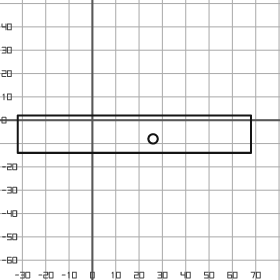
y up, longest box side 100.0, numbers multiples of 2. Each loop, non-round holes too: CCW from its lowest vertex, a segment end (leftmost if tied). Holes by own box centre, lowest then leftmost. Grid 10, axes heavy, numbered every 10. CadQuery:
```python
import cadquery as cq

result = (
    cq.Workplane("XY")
    .moveTo(-32.0, -14.0)
    .lineTo(68.0, -14.0)
    .lineTo(68.0, 2.0)
    .lineTo(-32.0, 2.0)
    .close()
    .moveTo(26.0, -8.0)
    .circle(2.0)
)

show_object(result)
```